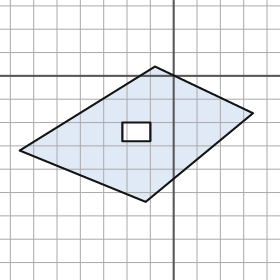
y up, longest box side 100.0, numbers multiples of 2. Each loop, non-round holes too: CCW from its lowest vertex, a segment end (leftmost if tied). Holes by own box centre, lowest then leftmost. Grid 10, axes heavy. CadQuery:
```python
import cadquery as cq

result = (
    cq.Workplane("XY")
    .moveTo(-12.0, -54.0)
    .lineTo(34.0, -16.0)
    .lineTo(-8.0, 4.0)
    .lineTo(-66.0, -32.0)
    .close()
    .moveTo(-22.0, -28.0)
    .lineTo(-10.0, -28.0)
    .lineTo(-10.0, -20.0)
    .lineTo(-22.0, -20.0)
    .close()
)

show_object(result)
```